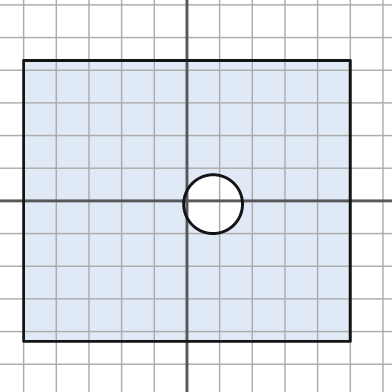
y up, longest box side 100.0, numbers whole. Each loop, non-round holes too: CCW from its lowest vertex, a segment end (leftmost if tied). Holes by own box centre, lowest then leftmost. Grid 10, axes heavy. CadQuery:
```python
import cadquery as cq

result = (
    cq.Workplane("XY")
    .moveTo(-50.0, -43.0)
    .lineTo(50.0, -43.0)
    .lineTo(50.0, 43.0)
    .lineTo(-50.0, 43.0)
    .close()
    .moveTo(8.0, -1.0)
    .circle(9.0)
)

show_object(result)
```